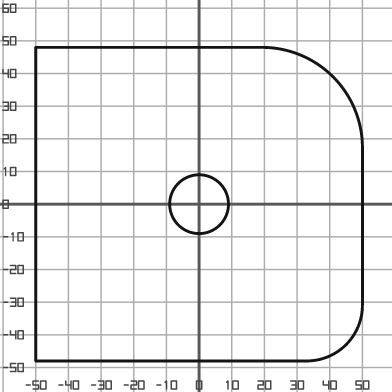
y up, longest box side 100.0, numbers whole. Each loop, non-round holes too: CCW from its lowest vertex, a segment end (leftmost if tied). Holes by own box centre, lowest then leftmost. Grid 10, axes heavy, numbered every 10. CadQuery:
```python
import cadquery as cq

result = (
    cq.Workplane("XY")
    .moveTo(-50.0, -48.0)
    .lineTo(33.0, -48.0)
    .threePointArc((45.0, -43.0), (50.0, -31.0))
    .lineTo(50.0, 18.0)
    .threePointArc((41.0, 39.0), (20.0, 48.0))
    .lineTo(-50.0, 48.0)
    .close()
    .moveTo(0.0, 0.0)
    .circle(9.0)
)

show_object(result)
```